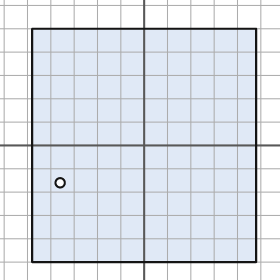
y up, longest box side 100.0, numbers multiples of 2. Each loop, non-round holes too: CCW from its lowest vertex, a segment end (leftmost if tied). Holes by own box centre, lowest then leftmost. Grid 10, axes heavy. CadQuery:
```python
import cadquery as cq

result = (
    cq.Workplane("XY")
    .moveTo(-48.0, -50.0)
    .lineTo(48.0, -50.0)
    .lineTo(48.0, 50.0)
    .lineTo(-48.0, 50.0)
    .close()
    .moveTo(-36.0, -16.0)
    .circle(2.0)
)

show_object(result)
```